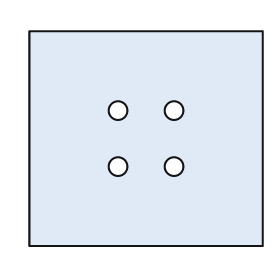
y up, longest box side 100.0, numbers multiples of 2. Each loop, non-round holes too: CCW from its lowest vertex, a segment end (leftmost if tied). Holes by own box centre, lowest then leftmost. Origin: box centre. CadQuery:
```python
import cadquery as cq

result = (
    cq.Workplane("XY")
    .moveTo(-50.0, -46.0)
    .lineTo(50.0, -46.0)
    .lineTo(50.0, 46.0)
    .lineTo(-50.0, 46.0)
    .close()
    .moveTo(-12.0, -12.0)
    .circle(4.0)
    .moveTo(12.0, -12.0)
    .circle(4.0)
    .moveTo(-12.0, 12.0)
    .circle(4.0)
    .moveTo(12.0, 12.0)
    .circle(4.0)
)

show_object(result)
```